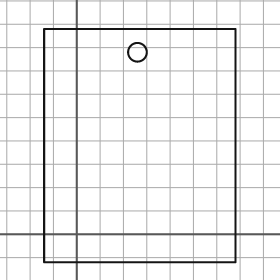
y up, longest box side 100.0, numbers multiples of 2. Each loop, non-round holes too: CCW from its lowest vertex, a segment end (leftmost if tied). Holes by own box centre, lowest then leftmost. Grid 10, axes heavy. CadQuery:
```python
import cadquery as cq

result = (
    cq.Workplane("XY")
    .moveTo(-14.0, -12.0)
    .lineTo(68.0, -12.0)
    .lineTo(68.0, 88.0)
    .lineTo(-14.0, 88.0)
    .close()
    .moveTo(26.0, 78.0)
    .circle(4.0)
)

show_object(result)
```